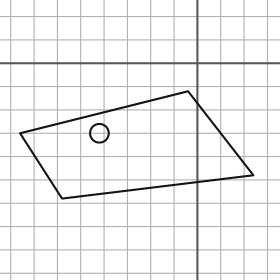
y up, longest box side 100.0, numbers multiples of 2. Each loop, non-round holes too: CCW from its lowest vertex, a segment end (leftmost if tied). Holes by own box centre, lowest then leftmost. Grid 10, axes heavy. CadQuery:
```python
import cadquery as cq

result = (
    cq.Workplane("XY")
    .moveTo(-58.0, -58.0)
    .lineTo(24.0, -48.0)
    .lineTo(-4.0, -12.0)
    .lineTo(-76.0, -30.0)
    .close()
    .moveTo(-42.0, -30.0)
    .circle(4.0)
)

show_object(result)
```